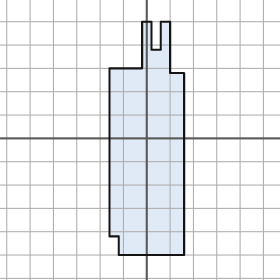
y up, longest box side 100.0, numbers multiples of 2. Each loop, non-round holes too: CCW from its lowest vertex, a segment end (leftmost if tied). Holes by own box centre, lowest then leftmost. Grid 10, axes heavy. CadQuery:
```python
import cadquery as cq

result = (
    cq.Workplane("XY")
    .moveTo(-12.0, -50.0)
    .lineTo(16.0, -50.0)
    .lineTo(16.0, 28.0)
    .lineTo(10.0, 28.0)
    .lineTo(10.0, 50.0)
    .lineTo(6.0, 50.0)
    .lineTo(6.0, 38.0)
    .lineTo(2.0, 38.0)
    .lineTo(2.0, 50.0)
    .lineTo(-2.0, 50.0)
    .lineTo(-2.0, 30.0)
    .lineTo(-16.0, 30.0)
    .lineTo(-16.0, -42.0)
    .lineTo(-12.0, -42.0)
    .close()
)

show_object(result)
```